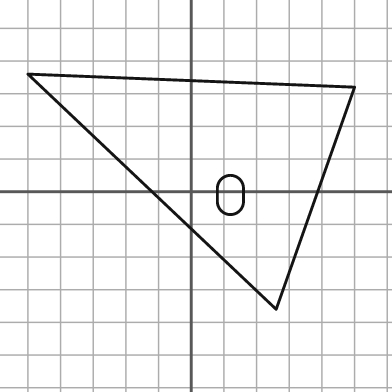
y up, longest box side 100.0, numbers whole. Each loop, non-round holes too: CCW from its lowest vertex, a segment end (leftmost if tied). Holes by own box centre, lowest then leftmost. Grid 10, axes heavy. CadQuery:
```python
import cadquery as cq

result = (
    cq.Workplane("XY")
    .moveTo(26.0, -36.0)
    .lineTo(50.0, 32.0)
    .lineTo(-50.0, 36.0)
    .close()
    .moveTo(8.0, -3.0)
    .threePointArc((12.0, -7.0), (16.0, -3.0))
    .lineTo(16.0, 1.0)
    .threePointArc((12.0, 5.0), (8.0, 1.0))
    .close()
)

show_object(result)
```